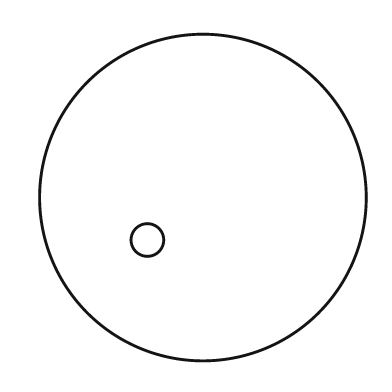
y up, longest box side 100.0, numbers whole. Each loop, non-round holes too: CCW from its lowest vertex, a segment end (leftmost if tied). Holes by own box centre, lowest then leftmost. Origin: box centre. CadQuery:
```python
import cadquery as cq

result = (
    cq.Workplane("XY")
    .moveTo(0.0, 0.0)
    .circle(50.0)
    .moveTo(-17.0, -13.0)
    .circle(5.0)
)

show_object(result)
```